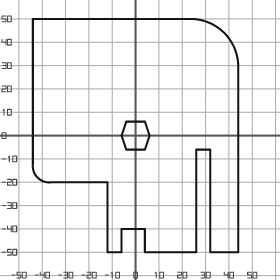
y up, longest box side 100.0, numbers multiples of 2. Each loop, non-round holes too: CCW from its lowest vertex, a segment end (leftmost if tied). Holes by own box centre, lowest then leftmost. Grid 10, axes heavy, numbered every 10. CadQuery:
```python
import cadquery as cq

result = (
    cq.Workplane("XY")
    .moveTo(-12.0, -50.0)
    .lineTo(-6.0, -50.0)
    .lineTo(-6.0, -40.0)
    .lineTo(4.0, -40.0)
    .lineTo(4.0, -50.0)
    .lineTo(26.0, -50.0)
    .lineTo(26.0, -6.0)
    .lineTo(32.0, -6.0)
    .lineTo(32.0, -50.0)
    .lineTo(44.0, -50.0)
    .lineTo(44.0, 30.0)
    .threePointArc((38.0, 44.0), (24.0, 50.0))
    .lineTo(-44.0, 50.0)
    .lineTo(-44.0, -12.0)
    .threePointArc((-42.0, -18.0), (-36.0, -20.0))
    .lineTo(-12.0, -20.0)
    .close()
    .moveTo(-4.0, -6.0)
    .lineTo(4.0, -6.0)
    .lineTo(6.0, 0.0)
    .lineTo(4.0, 6.0)
    .lineTo(-4.0, 6.0)
    .lineTo(-6.0, 0.0)
    .close()
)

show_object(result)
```